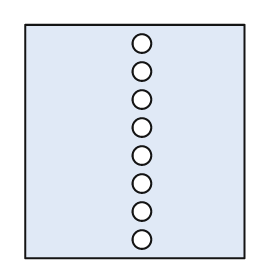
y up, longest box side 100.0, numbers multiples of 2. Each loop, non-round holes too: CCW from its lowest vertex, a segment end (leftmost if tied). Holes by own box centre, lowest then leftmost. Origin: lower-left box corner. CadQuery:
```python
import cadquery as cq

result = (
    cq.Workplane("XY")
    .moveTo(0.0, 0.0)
    .lineTo(94.0, 0.0)
    .lineTo(94.0, 100.0)
    .lineTo(0.0, 100.0)
    .close()
    .moveTo(50.0, 8.0)
    .circle(4.0)
    .moveTo(50.0, 20.0)
    .circle(4.0)
    .moveTo(50.0, 32.0)
    .circle(4.0)
    .moveTo(50.0, 44.0)
    .circle(4.0)
    .moveTo(50.0, 56.0)
    .circle(4.0)
    .moveTo(50.0, 68.0)
    .circle(4.0)
    .moveTo(50.0, 80.0)
    .circle(4.0)
    .moveTo(50.0, 92.0)
    .circle(4.0)
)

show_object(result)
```